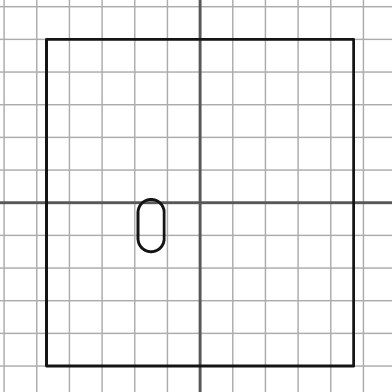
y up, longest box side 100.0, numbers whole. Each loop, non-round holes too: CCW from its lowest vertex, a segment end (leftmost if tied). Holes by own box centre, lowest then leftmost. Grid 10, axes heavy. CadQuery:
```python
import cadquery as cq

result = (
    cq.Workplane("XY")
    .moveTo(-47.0, -50.0)
    .lineTo(47.0, -50.0)
    .lineTo(47.0, 50.0)
    .lineTo(-47.0, 50.0)
    .close()
    .moveTo(-19.0, -11.0)
    .threePointArc((-15.0, -15.0), (-11.0, -11.0))
    .lineTo(-11.0, -3.0)
    .threePointArc((-15.0, 1.0), (-19.0, -3.0))
    .close()
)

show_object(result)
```